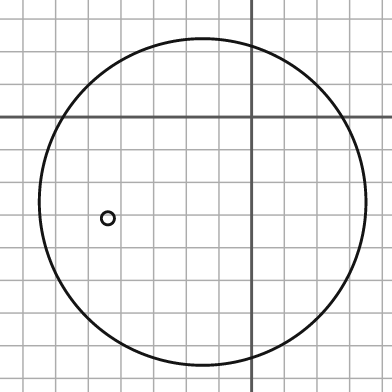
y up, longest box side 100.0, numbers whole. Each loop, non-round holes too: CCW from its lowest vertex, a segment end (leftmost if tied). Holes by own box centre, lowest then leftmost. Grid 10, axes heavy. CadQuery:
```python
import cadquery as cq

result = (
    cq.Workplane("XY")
    .moveTo(-15.0, -26.0)
    .circle(50.0)
    .moveTo(-44.0, -31.0)
    .circle(2.0)
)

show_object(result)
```